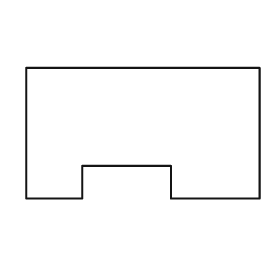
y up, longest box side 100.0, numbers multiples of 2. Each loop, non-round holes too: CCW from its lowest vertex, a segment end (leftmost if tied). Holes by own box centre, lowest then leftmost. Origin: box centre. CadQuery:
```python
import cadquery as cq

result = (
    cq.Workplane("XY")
    .moveTo(-50.0, -28.0)
    .lineTo(-26.0, -28.0)
    .lineTo(-26.0, -14.0)
    .lineTo(12.0, -14.0)
    .lineTo(12.0, -28.0)
    .lineTo(50.0, -28.0)
    .lineTo(50.0, 28.0)
    .lineTo(-50.0, 28.0)
    .close()
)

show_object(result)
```